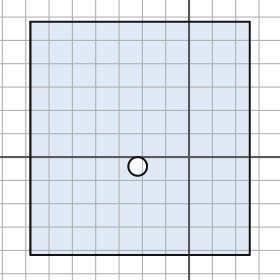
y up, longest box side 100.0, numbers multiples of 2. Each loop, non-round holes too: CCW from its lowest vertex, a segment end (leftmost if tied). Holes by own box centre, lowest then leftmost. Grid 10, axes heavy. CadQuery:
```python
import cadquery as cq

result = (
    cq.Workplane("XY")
    .moveTo(-68.0, -42.0)
    .lineTo(26.0, -42.0)
    .lineTo(26.0, 58.0)
    .lineTo(-68.0, 58.0)
    .close()
    .moveTo(-22.0, -4.0)
    .circle(4.0)
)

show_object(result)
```